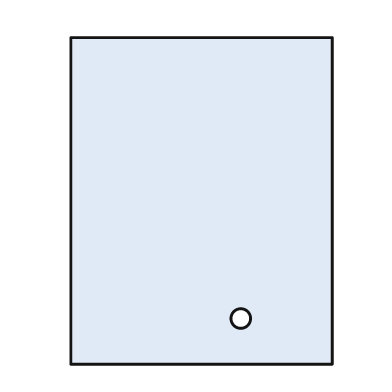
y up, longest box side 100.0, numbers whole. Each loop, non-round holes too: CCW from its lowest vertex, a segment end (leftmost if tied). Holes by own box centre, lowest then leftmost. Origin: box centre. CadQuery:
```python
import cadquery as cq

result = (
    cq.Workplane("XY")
    .moveTo(-40.0, -50.0)
    .lineTo(40.0, -50.0)
    .lineTo(40.0, 50.0)
    .lineTo(-40.0, 50.0)
    .close()
    .moveTo(12.0, -36.0)
    .circle(3.0)
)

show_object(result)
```